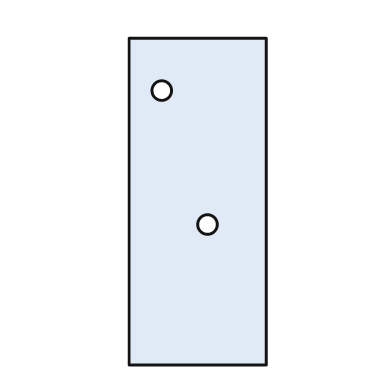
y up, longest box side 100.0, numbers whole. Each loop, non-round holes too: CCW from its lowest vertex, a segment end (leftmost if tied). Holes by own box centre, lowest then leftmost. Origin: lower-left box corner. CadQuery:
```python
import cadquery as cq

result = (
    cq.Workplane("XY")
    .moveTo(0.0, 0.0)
    .lineTo(42.0, 0.0)
    .lineTo(42.0, 100.0)
    .lineTo(0.0, 100.0)
    .close()
    .moveTo(24.0, 43.0)
    .circle(3.0)
    .moveTo(10.0, 84.0)
    .circle(3.0)
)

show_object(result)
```